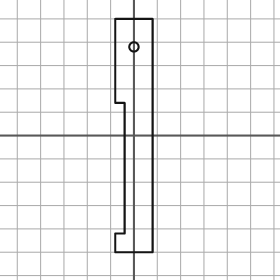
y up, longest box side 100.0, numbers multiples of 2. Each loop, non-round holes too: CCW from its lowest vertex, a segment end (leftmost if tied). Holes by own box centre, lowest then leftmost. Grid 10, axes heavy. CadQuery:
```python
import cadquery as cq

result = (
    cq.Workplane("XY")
    .moveTo(-8.0, -50.0)
    .lineTo(8.0, -50.0)
    .lineTo(8.0, 50.0)
    .lineTo(-8.0, 50.0)
    .lineTo(-8.0, 14.0)
    .lineTo(-4.0, 14.0)
    .lineTo(-4.0, -42.0)
    .lineTo(-8.0, -42.0)
    .close()
    .moveTo(0.0, 38.0)
    .circle(2.0)
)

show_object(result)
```